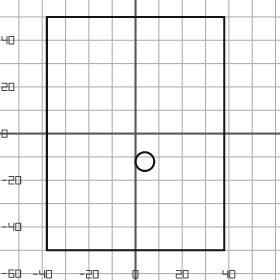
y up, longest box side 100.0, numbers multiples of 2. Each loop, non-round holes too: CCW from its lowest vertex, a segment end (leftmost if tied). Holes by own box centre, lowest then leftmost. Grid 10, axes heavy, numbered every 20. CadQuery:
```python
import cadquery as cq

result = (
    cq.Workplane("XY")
    .moveTo(-38.0, -50.0)
    .lineTo(38.0, -50.0)
    .lineTo(38.0, 50.0)
    .lineTo(-38.0, 50.0)
    .close()
    .moveTo(4.0, -12.0)
    .circle(4.0)
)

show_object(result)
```